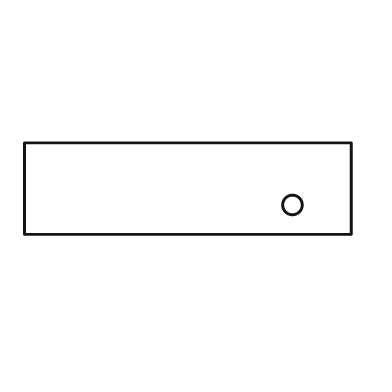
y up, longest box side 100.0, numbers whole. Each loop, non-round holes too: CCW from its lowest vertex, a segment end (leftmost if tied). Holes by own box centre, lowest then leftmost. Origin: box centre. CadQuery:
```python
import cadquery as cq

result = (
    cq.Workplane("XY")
    .moveTo(-50.0, -14.0)
    .lineTo(50.0, -14.0)
    .lineTo(50.0, 14.0)
    .lineTo(-50.0, 14.0)
    .close()
    .moveTo(32.0, -5.0)
    .circle(3.0)
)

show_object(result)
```